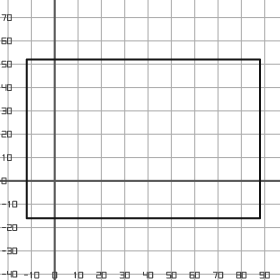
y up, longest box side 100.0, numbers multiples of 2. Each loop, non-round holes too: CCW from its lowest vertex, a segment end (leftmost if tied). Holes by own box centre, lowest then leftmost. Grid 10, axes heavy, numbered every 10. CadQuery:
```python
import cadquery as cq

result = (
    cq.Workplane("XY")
    .moveTo(-12.0, -16.0)
    .lineTo(88.0, -16.0)
    .lineTo(88.0, 52.0)
    .lineTo(-12.0, 52.0)
    .close()
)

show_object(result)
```